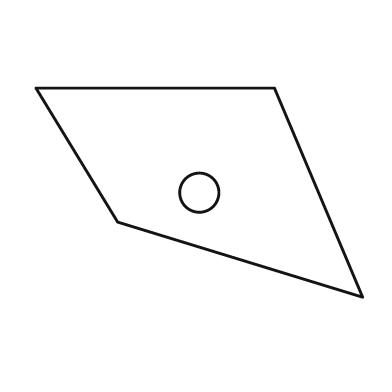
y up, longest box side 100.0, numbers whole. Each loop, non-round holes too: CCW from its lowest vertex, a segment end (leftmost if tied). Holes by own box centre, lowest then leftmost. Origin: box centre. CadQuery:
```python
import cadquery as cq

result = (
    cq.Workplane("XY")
    .moveTo(50.0, -32.0)
    .lineTo(23.0, 32.0)
    .lineTo(-50.0, 32.0)
    .lineTo(-25.0, -9.0)
    .close()
    .moveTo(0.0, 0.0)
    .circle(6.0)
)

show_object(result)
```